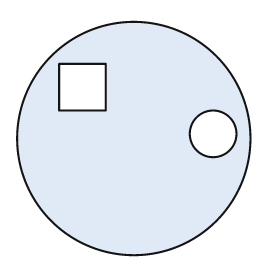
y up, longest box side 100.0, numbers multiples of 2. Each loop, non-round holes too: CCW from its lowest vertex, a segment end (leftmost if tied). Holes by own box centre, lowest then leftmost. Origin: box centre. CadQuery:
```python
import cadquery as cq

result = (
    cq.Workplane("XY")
    .moveTo(0.0, 0.0)
    .circle(50.0)
    .moveTo(34.0, 2.0)
    .circle(10.0)
    .moveTo(-32.0, 12.0)
    .lineTo(-12.0, 12.0)
    .lineTo(-12.0, 32.0)
    .lineTo(-32.0, 32.0)
    .close()
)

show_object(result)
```